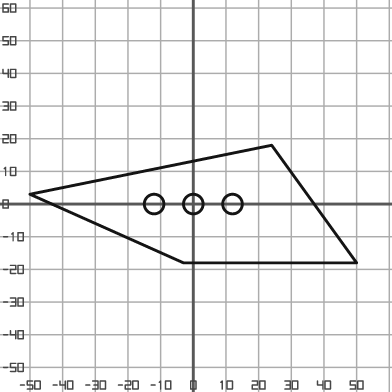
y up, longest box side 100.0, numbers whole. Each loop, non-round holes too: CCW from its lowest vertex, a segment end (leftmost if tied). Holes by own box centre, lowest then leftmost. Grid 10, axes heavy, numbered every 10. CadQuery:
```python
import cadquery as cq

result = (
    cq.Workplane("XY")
    .moveTo(-3.0, -18.0)
    .lineTo(50.0, -18.0)
    .lineTo(24.0, 18.0)
    .lineTo(-50.0, 3.0)
    .close()
    .moveTo(-12.0, 0.0)
    .circle(3.0)
    .moveTo(0.0, 0.0)
    .circle(3.0)
    .moveTo(12.0, 0.0)
    .circle(3.0)
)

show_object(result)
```